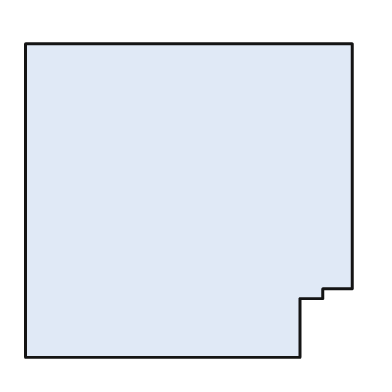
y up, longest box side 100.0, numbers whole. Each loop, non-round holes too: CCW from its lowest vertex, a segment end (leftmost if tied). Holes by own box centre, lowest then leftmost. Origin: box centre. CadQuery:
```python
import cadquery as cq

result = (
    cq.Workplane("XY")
    .moveTo(-50.0, -48.0)
    .lineTo(34.0, -48.0)
    .lineTo(34.0, -30.0)
    .lineTo(41.0, -30.0)
    .lineTo(41.0, -27.0)
    .lineTo(50.0, -27.0)
    .lineTo(50.0, 48.0)
    .lineTo(-50.0, 48.0)
    .close()
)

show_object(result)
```